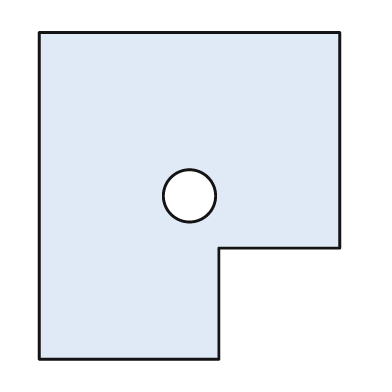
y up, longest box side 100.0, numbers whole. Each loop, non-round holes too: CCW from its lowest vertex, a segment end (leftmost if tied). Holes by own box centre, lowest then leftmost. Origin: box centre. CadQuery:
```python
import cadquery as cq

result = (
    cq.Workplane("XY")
    .moveTo(-46.0, -50.0)
    .lineTo(9.0, -50.0)
    .lineTo(9.0, -16.0)
    .lineTo(46.0, -16.0)
    .lineTo(46.0, 50.0)
    .lineTo(-46.0, 50.0)
    .close()
    .moveTo(0.0, 0.0)
    .circle(8.0)
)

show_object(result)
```